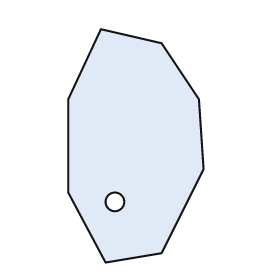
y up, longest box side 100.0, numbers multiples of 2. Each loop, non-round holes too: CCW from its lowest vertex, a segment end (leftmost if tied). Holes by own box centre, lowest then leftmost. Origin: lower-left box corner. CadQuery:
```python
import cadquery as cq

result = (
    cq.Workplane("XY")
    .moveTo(16.0, 0.0)
    .lineTo(40.0, 4.0)
    .lineTo(58.0, 40.0)
    .lineTo(56.0, 70.0)
    .lineTo(40.0, 94.0)
    .lineTo(14.0, 100.0)
    .lineTo(0.0, 70.0)
    .lineTo(0.0, 30.0)
    .close()
    .moveTo(20.0, 26.0)
    .circle(4.0)
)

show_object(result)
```